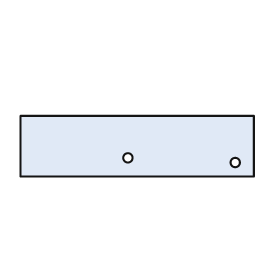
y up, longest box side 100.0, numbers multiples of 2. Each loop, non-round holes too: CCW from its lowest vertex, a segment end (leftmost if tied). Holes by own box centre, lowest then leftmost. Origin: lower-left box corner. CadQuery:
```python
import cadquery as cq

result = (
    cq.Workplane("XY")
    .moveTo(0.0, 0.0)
    .lineTo(100.0, 0.0)
    .lineTo(100.0, 26.0)
    .lineTo(0.0, 26.0)
    .close()
    .moveTo(92.0, 6.0)
    .circle(2.0)
    .moveTo(46.0, 8.0)
    .circle(2.0)
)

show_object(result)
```